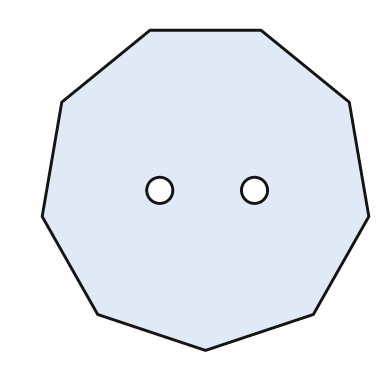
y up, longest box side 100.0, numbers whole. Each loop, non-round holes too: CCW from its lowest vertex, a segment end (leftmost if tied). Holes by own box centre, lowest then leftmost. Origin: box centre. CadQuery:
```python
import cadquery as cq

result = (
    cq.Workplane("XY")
    .moveTo(0.0, -49.0)
    .lineTo(33.0, -38.0)
    .lineTo(50.0, -8.0)
    .lineTo(44.0, 27.0)
    .lineTo(17.0, 49.0)
    .lineTo(-17.0, 49.0)
    .lineTo(-44.0, 27.0)
    .lineTo(-50.0, -8.0)
    .lineTo(-33.0, -38.0)
    .close()
    .moveTo(-14.0, 0.0)
    .circle(4.0)
    .moveTo(15.0, 0.0)
    .circle(4.0)
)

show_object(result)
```